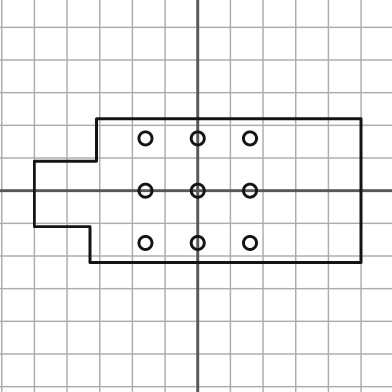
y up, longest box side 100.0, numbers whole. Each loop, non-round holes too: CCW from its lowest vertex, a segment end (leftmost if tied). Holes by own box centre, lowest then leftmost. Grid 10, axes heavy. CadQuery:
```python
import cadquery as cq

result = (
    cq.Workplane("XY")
    .moveTo(-33.0, -22.0)
    .lineTo(50.0, -22.0)
    .lineTo(50.0, 22.0)
    .lineTo(-31.0, 22.0)
    .lineTo(-31.0, 9.0)
    .lineTo(-50.0, 9.0)
    .lineTo(-50.0, -11.0)
    .lineTo(-33.0, -11.0)
    .close()
    .moveTo(-16.0, -16.0)
    .circle(2.0)
    .moveTo(0.0, -16.0)
    .circle(2.0)
    .moveTo(16.0, -16.0)
    .circle(2.0)
    .moveTo(-16.0, 0.0)
    .circle(2.0)
    .moveTo(0.0, 0.0)
    .circle(2.0)
    .moveTo(16.0, 0.0)
    .circle(2.0)
    .moveTo(-16.0, 16.0)
    .circle(2.0)
    .moveTo(0.0, 16.0)
    .circle(2.0)
    .moveTo(16.0, 16.0)
    .circle(2.0)
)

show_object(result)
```